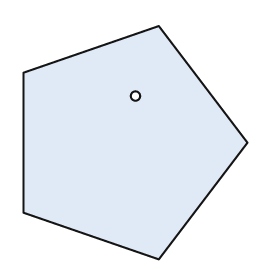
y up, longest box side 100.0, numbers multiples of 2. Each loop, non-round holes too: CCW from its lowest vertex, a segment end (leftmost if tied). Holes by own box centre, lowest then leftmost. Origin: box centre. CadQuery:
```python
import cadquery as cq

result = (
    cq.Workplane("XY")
    .moveTo(10.0, -50.0)
    .lineTo(48.0, 0.0)
    .lineTo(10.0, 50.0)
    .lineTo(-48.0, 30.0)
    .lineTo(-48.0, -30.0)
    .close()
    .moveTo(0.0, 20.0)
    .circle(2.0)
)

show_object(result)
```